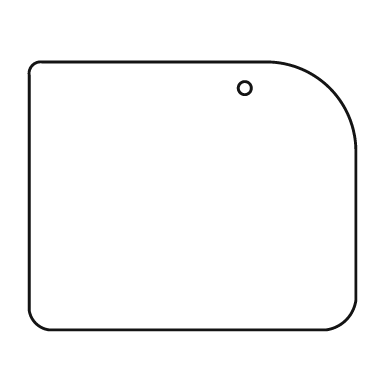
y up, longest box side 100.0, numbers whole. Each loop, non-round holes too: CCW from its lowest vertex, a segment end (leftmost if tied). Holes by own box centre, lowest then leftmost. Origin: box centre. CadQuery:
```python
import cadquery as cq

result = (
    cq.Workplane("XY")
    .moveTo(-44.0, -41.0)
    .lineTo(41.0, -41.0)
    .threePointArc((47.0, -38.0), (50.0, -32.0))
    .lineTo(50.0, 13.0)
    .threePointArc((42.0, 33.0), (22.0, 41.0))
    .lineTo(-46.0, 41.0)
    .threePointArc((-49.0, 40.0), (-50.0, 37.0))
    .lineTo(-50.0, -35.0)
    .threePointArc((-48.0, -39.0), (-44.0, -41.0))
    .close()
    .moveTo(16.0, 33.0)
    .circle(2.0)
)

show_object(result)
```